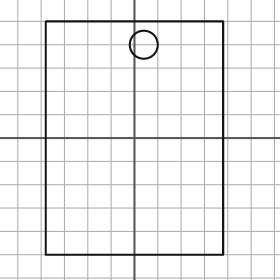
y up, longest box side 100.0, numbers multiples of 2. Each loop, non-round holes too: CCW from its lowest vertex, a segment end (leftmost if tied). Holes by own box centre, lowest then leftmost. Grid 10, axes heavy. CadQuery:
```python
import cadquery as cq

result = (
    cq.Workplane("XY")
    .moveTo(-38.0, -50.0)
    .lineTo(38.0, -50.0)
    .lineTo(38.0, 50.0)
    .lineTo(-38.0, 50.0)
    .close()
    .moveTo(4.0, 40.0)
    .circle(6.0)
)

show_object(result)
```